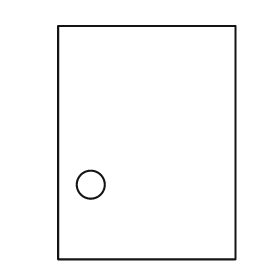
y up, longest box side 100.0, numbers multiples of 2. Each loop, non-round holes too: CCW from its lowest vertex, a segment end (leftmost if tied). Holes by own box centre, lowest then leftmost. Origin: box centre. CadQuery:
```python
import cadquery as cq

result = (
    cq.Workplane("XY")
    .moveTo(-38.0, -50.0)
    .lineTo(38.0, -50.0)
    .lineTo(38.0, 50.0)
    .lineTo(-38.0, 50.0)
    .close()
    .moveTo(-24.0, -18.0)
    .circle(6.0)
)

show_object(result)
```